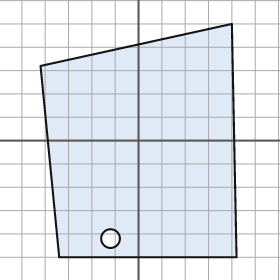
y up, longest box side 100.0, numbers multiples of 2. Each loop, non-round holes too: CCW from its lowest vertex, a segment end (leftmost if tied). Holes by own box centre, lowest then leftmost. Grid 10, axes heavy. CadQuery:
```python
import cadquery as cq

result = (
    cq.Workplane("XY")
    .moveTo(-34.0, -50.0)
    .lineTo(42.0, -50.0)
    .lineTo(40.0, 50.0)
    .lineTo(-42.0, 32.0)
    .close()
    .moveTo(-12.0, -42.0)
    .circle(4.0)
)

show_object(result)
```